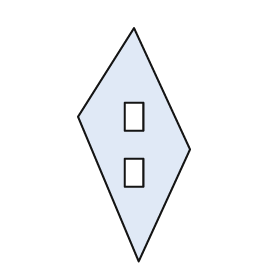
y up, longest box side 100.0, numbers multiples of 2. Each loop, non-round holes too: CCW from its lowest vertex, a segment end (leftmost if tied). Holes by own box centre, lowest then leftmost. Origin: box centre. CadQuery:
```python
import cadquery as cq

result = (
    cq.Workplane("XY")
    .moveTo(2.0, -50.0)
    .lineTo(24.0, -2.0)
    .lineTo(0.0, 50.0)
    .lineTo(-24.0, 12.0)
    .close()
    .moveTo(-4.0, -18.0)
    .lineTo(4.0, -18.0)
    .lineTo(4.0, -6.0)
    .lineTo(-4.0, -6.0)
    .close()
    .moveTo(-4.0, 6.0)
    .lineTo(4.0, 6.0)
    .lineTo(4.0, 18.0)
    .lineTo(-4.0, 18.0)
    .close()
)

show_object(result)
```